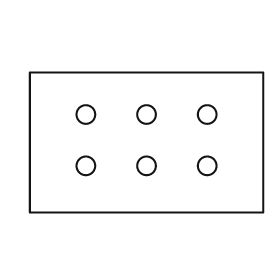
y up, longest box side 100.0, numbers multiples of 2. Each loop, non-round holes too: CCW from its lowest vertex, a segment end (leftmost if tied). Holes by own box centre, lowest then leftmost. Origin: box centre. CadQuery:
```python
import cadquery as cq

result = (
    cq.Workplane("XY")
    .moveTo(-50.0, -30.0)
    .lineTo(50.0, -30.0)
    .lineTo(50.0, 30.0)
    .lineTo(-50.0, 30.0)
    .close()
    .moveTo(-26.0, -10.0)
    .circle(4.0)
    .moveTo(0.0, -10.0)
    .circle(4.0)
    .moveTo(26.0, -10.0)
    .circle(4.0)
    .moveTo(-26.0, 12.0)
    .circle(4.0)
    .moveTo(0.0, 12.0)
    .circle(4.0)
    .moveTo(26.0, 12.0)
    .circle(4.0)
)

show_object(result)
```